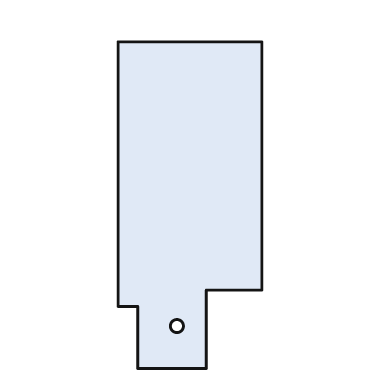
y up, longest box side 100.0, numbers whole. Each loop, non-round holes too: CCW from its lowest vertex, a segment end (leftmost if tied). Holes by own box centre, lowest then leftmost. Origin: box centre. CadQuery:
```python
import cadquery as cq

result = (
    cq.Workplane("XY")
    .moveTo(-16.0, -50.0)
    .lineTo(5.0, -50.0)
    .lineTo(5.0, -26.0)
    .lineTo(22.0, -26.0)
    .lineTo(22.0, 50.0)
    .lineTo(-22.0, 50.0)
    .lineTo(-22.0, -31.0)
    .lineTo(-16.0, -31.0)
    .close()
    .moveTo(-4.0, -37.0)
    .circle(2.0)
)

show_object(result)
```